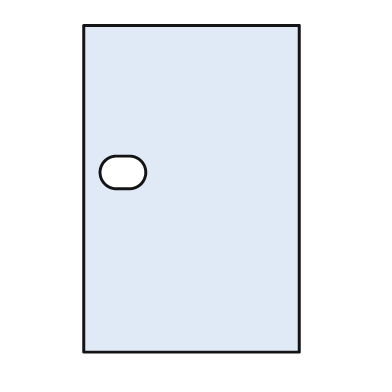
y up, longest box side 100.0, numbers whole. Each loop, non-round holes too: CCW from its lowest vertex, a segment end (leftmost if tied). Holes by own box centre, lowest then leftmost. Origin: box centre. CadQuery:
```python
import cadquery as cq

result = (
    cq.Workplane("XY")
    .moveTo(-33.0, -50.0)
    .lineTo(33.0, -50.0)
    .lineTo(33.0, 50.0)
    .lineTo(-33.0, 50.0)
    .close()
    .moveTo(-23.0, 0.0)
    .lineTo(-19.0, 0.0)
    .threePointArc((-14.0, 5.0), (-19.0, 10.0))
    .lineTo(-23.0, 10.0)
    .threePointArc((-28.0, 5.0), (-23.0, 0.0))
    .close()
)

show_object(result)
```